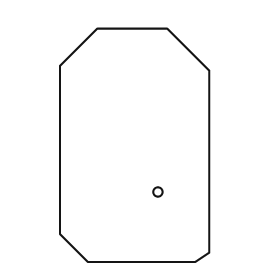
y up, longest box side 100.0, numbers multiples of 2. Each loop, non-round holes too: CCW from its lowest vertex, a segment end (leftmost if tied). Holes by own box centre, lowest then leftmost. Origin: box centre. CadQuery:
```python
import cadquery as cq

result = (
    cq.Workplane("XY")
    .moveTo(-20.0, -50.0)
    .lineTo(26.0, -50.0)
    .lineTo(32.0, -46.0)
    .lineTo(32.0, 32.0)
    .lineTo(14.0, 50.0)
    .lineTo(-16.0, 50.0)
    .lineTo(-32.0, 34.0)
    .lineTo(-32.0, -38.0)
    .close()
    .moveTo(10.0, -20.0)
    .circle(2.0)
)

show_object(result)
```